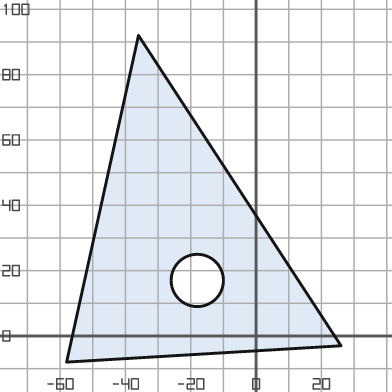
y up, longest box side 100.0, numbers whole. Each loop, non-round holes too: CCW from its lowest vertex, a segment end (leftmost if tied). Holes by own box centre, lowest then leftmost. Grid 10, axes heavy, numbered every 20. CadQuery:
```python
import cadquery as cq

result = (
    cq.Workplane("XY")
    .moveTo(-58.0, -8.0)
    .lineTo(26.0, -3.0)
    .lineTo(-36.0, 92.0)
    .close()
    .moveTo(-18.0, 17.0)
    .circle(8.0)
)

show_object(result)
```